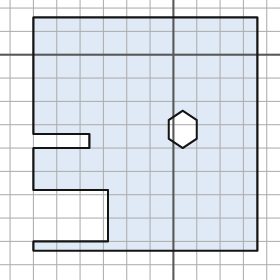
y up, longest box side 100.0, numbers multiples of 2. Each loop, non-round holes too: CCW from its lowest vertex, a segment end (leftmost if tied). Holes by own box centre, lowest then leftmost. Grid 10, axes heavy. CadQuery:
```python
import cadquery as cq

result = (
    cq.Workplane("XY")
    .moveTo(-60.0, -84.0)
    .lineTo(36.0, -84.0)
    .lineTo(36.0, 16.0)
    .lineTo(-60.0, 16.0)
    .lineTo(-60.0, -34.0)
    .lineTo(-36.0, -34.0)
    .lineTo(-36.0, -40.0)
    .lineTo(-60.0, -40.0)
    .lineTo(-60.0, -58.0)
    .lineTo(-28.0, -58.0)
    .lineTo(-28.0, -80.0)
    .lineTo(-60.0, -80.0)
    .close()
    .moveTo(4.0, -40.0)
    .lineTo(10.0, -36.0)
    .lineTo(10.0, -28.0)
    .lineTo(4.0, -24.0)
    .lineTo(-2.0, -28.0)
    .lineTo(-2.0, -36.0)
    .close()
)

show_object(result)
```